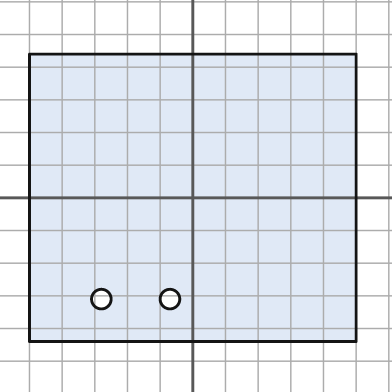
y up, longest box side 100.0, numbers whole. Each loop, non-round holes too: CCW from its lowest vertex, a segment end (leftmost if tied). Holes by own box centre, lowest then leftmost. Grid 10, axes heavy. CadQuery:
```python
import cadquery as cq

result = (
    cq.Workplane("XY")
    .moveTo(-50.0, -44.0)
    .lineTo(50.0, -44.0)
    .lineTo(50.0, 44.0)
    .lineTo(-50.0, 44.0)
    .close()
    .moveTo(-28.0, -31.0)
    .circle(3.0)
    .moveTo(-7.0, -31.0)
    .circle(3.0)
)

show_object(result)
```